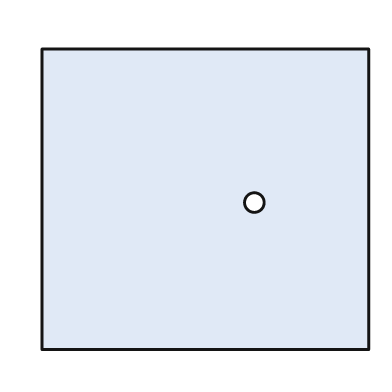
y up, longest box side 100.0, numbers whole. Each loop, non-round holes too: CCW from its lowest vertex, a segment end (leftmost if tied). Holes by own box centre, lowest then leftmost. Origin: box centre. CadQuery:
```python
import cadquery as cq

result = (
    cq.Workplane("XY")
    .moveTo(-50.0, -46.0)
    .lineTo(50.0, -46.0)
    .lineTo(50.0, 46.0)
    .lineTo(-50.0, 46.0)
    .close()
    .moveTo(15.0, -1.0)
    .circle(3.0)
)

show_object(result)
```